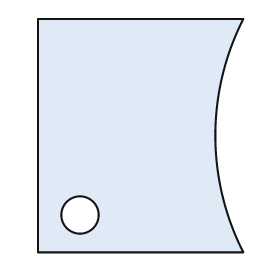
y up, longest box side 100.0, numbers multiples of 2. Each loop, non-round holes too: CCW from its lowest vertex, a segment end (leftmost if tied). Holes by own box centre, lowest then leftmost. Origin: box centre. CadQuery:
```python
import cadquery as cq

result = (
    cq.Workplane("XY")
    .moveTo(-44.0, -50.0)
    .lineTo(44.0, -50.0)
    .threePointArc((32.0, 0.0), (44.0, 50.0))
    .lineTo(-44.0, 50.0)
    .close()
    .moveTo(-26.0, -34.0)
    .circle(8.0)
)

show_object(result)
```